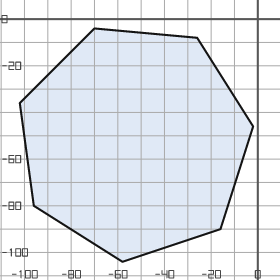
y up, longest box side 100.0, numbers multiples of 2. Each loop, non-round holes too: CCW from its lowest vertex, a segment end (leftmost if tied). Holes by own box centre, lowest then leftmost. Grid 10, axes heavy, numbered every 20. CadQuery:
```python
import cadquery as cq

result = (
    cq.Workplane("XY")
    .moveTo(-58.0, -104.0)
    .lineTo(-16.0, -90.0)
    .lineTo(-2.0, -46.0)
    .lineTo(-26.0, -8.0)
    .lineTo(-70.0, -4.0)
    .lineTo(-102.0, -36.0)
    .lineTo(-96.0, -80.0)
    .close()
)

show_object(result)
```